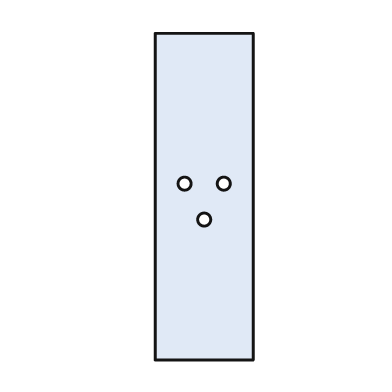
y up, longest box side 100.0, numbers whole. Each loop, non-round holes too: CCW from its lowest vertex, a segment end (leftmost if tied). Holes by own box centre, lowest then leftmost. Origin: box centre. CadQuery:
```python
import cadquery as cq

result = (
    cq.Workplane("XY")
    .moveTo(-15.0, -50.0)
    .lineTo(15.0, -50.0)
    .lineTo(15.0, 50.0)
    .lineTo(-15.0, 50.0)
    .close()
    .moveTo(0.0, -7.0)
    .circle(2.0)
    .moveTo(-6.0, 4.0)
    .circle(2.0)
    .moveTo(6.0, 4.0)
    .circle(2.0)
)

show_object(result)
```